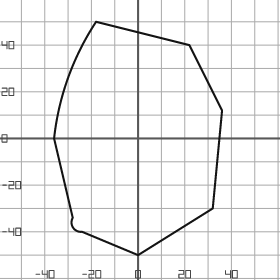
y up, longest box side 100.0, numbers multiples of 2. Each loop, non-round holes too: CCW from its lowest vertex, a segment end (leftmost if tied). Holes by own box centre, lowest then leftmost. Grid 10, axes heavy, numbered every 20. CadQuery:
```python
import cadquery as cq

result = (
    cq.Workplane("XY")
    .moveTo(0.0, -50.0)
    .lineTo(32.0, -30.0)
    .lineTo(36.0, 12.0)
    .lineTo(22.0, 40.0)
    .lineTo(-18.0, 50.0)
    .threePointArc((-30.0, 26.0), (-36.0, 0.0))
    .lineTo(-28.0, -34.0)
    .threePointArc((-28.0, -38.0), (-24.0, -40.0))
    .close()
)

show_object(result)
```